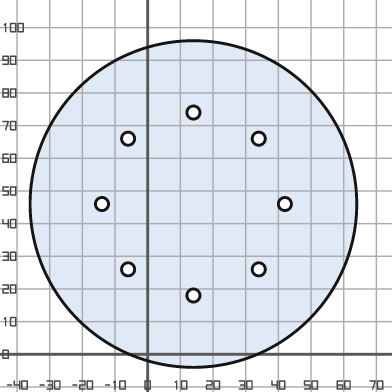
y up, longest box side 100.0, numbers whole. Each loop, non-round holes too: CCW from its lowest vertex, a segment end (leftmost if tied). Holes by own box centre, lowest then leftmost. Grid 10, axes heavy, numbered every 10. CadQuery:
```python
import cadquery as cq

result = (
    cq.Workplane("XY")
    .moveTo(14.0, 46.0)
    .circle(50.0)
    .moveTo(14.0, 18.0)
    .circle(2.0)
    .moveTo(-6.0, 26.0)
    .circle(2.0)
    .moveTo(34.0, 26.0)
    .circle(2.0)
    .moveTo(-14.0, 46.0)
    .circle(2.0)
    .moveTo(42.0, 46.0)
    .circle(2.0)
    .moveTo(-6.0, 66.0)
    .circle(2.0)
    .moveTo(34.0, 66.0)
    .circle(2.0)
    .moveTo(14.0, 74.0)
    .circle(2.0)
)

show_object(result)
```